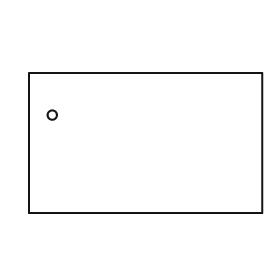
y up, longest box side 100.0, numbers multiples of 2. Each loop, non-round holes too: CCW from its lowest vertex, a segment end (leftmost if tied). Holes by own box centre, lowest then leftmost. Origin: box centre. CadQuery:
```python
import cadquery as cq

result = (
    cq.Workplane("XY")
    .moveTo(-50.0, -30.0)
    .lineTo(50.0, -30.0)
    .lineTo(50.0, 30.0)
    .lineTo(-50.0, 30.0)
    .close()
    .moveTo(-40.0, 12.0)
    .circle(2.0)
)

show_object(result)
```